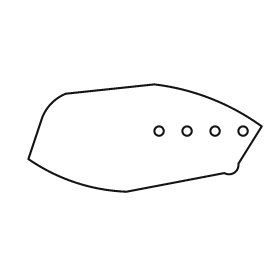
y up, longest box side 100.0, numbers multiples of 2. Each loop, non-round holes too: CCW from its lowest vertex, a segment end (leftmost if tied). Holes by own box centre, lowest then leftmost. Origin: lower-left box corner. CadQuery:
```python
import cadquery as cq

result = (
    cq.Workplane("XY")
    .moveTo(42.0, 0.0)
    .lineTo(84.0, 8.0)
    .threePointArc((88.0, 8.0), (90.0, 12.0))
    .lineTo(100.0, 28.0)
    .threePointArc((78.0, 40.0), (54.0, 46.0))
    .lineTo(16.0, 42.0)
    .threePointArc((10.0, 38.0), (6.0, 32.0))
    .lineTo(0.0, 14.0)
    .threePointArc((20.0, 4.0), (42.0, 0.0))
    .close()
    .moveTo(56.0, 26.0)
    .circle(2.0)
    .moveTo(68.0, 26.0)
    .circle(2.0)
    .moveTo(80.0, 26.0)
    .circle(2.0)
    .moveTo(92.0, 26.0)
    .circle(2.0)
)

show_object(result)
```